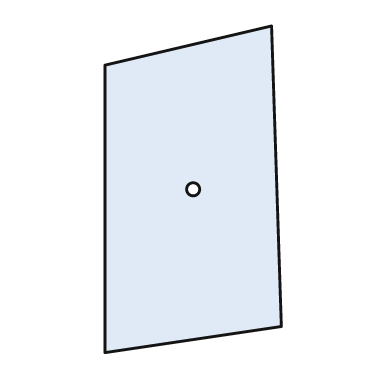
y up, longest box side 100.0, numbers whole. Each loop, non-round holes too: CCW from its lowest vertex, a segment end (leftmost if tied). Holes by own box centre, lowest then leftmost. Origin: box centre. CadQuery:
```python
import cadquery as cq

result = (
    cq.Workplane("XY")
    .moveTo(-27.0, -50.0)
    .lineTo(27.0, -42.0)
    .lineTo(24.0, 50.0)
    .lineTo(-27.0, 38.0)
    .close()
    .moveTo(0.0, 0.0)
    .circle(2.0)
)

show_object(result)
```